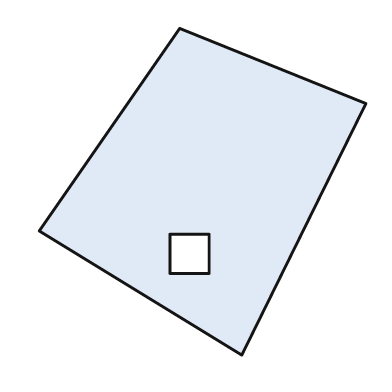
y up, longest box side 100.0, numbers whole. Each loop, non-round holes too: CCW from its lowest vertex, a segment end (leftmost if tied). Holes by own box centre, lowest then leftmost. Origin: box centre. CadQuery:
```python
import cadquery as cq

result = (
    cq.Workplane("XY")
    .moveTo(12.0, -50.0)
    .lineTo(50.0, 27.0)
    .lineTo(-7.0, 50.0)
    .lineTo(-50.0, -12.0)
    .close()
    .moveTo(-10.0, -25.0)
    .lineTo(2.0, -25.0)
    .lineTo(2.0, -13.0)
    .lineTo(-10.0, -13.0)
    .close()
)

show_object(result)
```